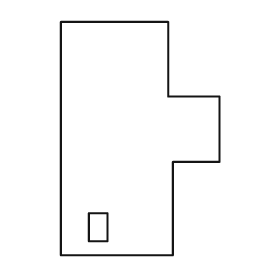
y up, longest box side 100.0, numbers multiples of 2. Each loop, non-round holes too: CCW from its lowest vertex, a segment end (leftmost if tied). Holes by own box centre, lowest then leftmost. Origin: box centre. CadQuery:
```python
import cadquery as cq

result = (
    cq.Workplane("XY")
    .moveTo(-34.0, -50.0)
    .lineTo(14.0, -50.0)
    .lineTo(14.0, -10.0)
    .lineTo(34.0, -10.0)
    .lineTo(34.0, 18.0)
    .lineTo(12.0, 18.0)
    .lineTo(12.0, 50.0)
    .lineTo(-34.0, 50.0)
    .close()
    .moveTo(-22.0, -44.0)
    .lineTo(-14.0, -44.0)
    .lineTo(-14.0, -32.0)
    .lineTo(-22.0, -32.0)
    .close()
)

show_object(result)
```